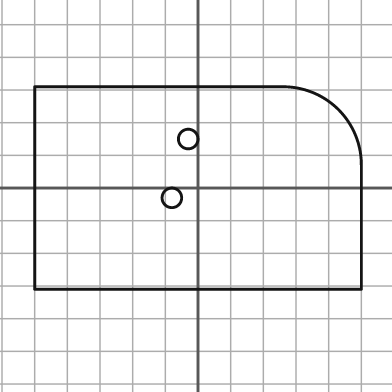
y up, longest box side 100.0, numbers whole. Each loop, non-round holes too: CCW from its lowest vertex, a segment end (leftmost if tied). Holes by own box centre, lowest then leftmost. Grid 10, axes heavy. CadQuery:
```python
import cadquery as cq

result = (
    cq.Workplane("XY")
    .moveTo(-50.0, -31.0)
    .lineTo(50.0, -31.0)
    .lineTo(50.0, 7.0)
    .threePointArc((43.0, 24.0), (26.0, 31.0))
    .lineTo(-50.0, 31.0)
    .close()
    .moveTo(-8.0, -3.0)
    .circle(3.0)
    .moveTo(-3.0, 15.0)
    .circle(3.0)
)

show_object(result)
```